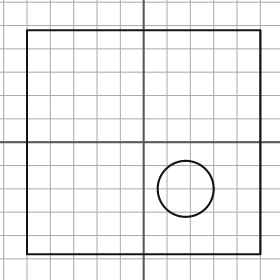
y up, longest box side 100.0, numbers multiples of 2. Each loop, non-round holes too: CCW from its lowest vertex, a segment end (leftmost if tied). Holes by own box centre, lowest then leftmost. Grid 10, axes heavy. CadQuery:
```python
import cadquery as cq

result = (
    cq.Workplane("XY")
    .moveTo(-50.0, -48.0)
    .lineTo(50.0, -48.0)
    .lineTo(50.0, 48.0)
    .lineTo(-50.0, 48.0)
    .close()
    .moveTo(18.0, -20.0)
    .circle(12.0)
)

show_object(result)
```